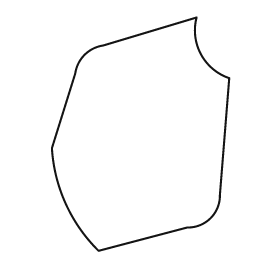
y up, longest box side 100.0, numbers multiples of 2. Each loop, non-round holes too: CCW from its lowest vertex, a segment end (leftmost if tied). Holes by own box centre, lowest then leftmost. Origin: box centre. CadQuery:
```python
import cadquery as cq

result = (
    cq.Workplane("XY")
    .moveTo(-18.0, -50.0)
    .lineTo(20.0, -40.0)
    .threePointArc((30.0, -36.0), (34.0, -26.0))
    .lineTo(38.0, 24.0)
    .threePointArc((26.0, 34.0), (24.0, 50.0))
    .lineTo(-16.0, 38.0)
    .threePointArc((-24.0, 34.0), (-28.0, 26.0))
    .lineTo(-38.0, -6.0)
    .threePointArc((-32.0, -30.0), (-18.0, -50.0))
    .close()
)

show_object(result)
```